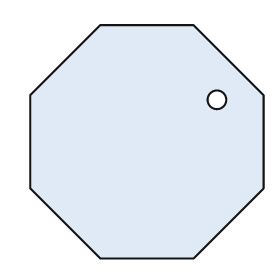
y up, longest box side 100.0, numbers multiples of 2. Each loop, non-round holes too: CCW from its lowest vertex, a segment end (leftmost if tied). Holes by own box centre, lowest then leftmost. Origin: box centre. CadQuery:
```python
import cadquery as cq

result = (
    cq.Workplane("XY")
    .moveTo(-20.0, -50.0)
    .lineTo(20.0, -50.0)
    .lineTo(50.0, -20.0)
    .lineTo(50.0, 20.0)
    .lineTo(20.0, 50.0)
    .lineTo(-20.0, 50.0)
    .lineTo(-50.0, 20.0)
    .lineTo(-50.0, -20.0)
    .close()
    .moveTo(30.0, 18.0)
    .circle(4.0)
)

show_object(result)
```